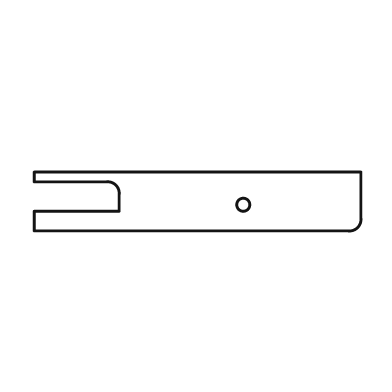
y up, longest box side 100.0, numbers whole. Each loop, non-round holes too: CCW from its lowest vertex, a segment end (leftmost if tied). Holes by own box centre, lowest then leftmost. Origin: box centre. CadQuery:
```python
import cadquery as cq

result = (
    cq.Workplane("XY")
    .moveTo(-50.0, -9.0)
    .lineTo(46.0, -9.0)
    .threePointArc((49.0, -8.0), (50.0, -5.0))
    .lineTo(50.0, 9.0)
    .lineTo(-50.0, 9.0)
    .lineTo(-50.0, 6.0)
    .lineTo(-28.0, 6.0)
    .threePointArc((-25.0, 5.0), (-24.0, 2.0))
    .lineTo(-24.0, -3.0)
    .lineTo(-50.0, -3.0)
    .close()
    .moveTo(14.0, -1.0)
    .circle(2.0)
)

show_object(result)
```